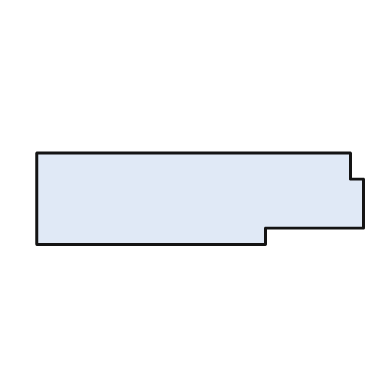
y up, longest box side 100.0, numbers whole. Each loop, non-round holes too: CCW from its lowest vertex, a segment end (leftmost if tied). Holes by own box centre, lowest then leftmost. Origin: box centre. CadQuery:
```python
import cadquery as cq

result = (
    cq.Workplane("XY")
    .moveTo(-50.0, -14.0)
    .lineTo(20.0, -14.0)
    .lineTo(20.0, -9.0)
    .lineTo(50.0, -9.0)
    .lineTo(50.0, 6.0)
    .lineTo(46.0, 6.0)
    .lineTo(46.0, 14.0)
    .lineTo(-50.0, 14.0)
    .close()
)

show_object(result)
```